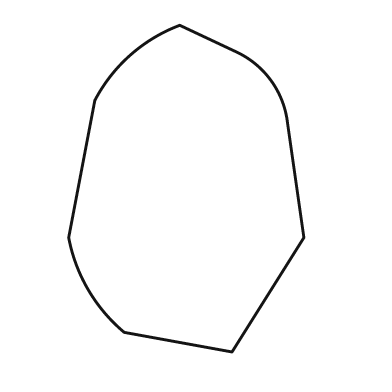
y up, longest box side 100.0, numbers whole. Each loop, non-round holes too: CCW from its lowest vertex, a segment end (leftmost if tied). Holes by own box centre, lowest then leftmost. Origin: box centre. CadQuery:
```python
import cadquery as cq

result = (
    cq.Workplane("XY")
    .moveTo(14.0, -50.0)
    .lineTo(36.0, -15.0)
    .lineTo(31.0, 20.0)
    .threePointArc((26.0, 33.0), (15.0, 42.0))
    .lineTo(-2.0, 50.0)
    .threePointArc((-17.0, 41.0), (-28.0, 27.0))
    .lineTo(-36.0, -15.0)
    .threePointArc((-30.0, -31.0), (-19.0, -44.0))
    .close()
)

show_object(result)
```